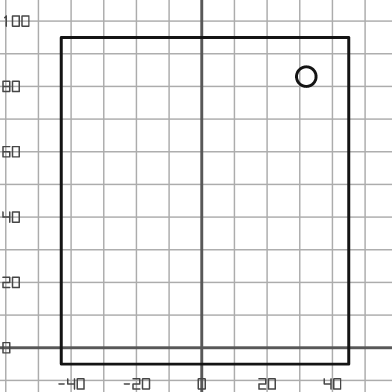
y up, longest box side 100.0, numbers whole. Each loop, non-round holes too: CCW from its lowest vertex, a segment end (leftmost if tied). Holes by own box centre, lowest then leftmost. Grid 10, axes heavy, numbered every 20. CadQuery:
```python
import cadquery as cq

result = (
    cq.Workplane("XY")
    .moveTo(-43.0, -5.0)
    .lineTo(45.0, -5.0)
    .lineTo(45.0, 95.0)
    .lineTo(-43.0, 95.0)
    .close()
    .moveTo(32.0, 83.0)
    .circle(3.0)
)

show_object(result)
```